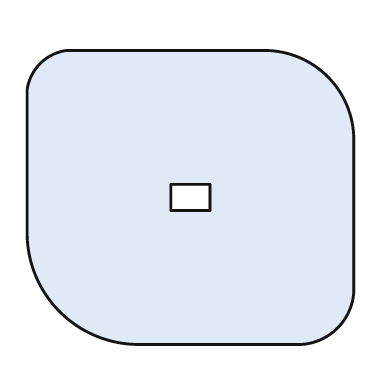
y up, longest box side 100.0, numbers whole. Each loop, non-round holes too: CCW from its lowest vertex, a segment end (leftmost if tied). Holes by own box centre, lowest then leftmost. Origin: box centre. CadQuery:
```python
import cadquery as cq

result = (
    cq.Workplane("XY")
    .moveTo(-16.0, -45.0)
    .lineTo(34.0, -45.0)
    .threePointArc((45.0, -40.0), (50.0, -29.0))
    .lineTo(50.0, 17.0)
    .threePointArc((42.0, 37.0), (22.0, 45.0))
    .lineTo(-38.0, 45.0)
    .threePointArc((-46.0, 41.0), (-50.0, 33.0))
    .lineTo(-50.0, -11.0)
    .threePointArc((-40.0, -35.0), (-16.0, -45.0))
    .close()
    .moveTo(-6.0, -4.0)
    .lineTo(6.0, -4.0)
    .lineTo(6.0, 4.0)
    .lineTo(-6.0, 4.0)
    .close()
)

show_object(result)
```